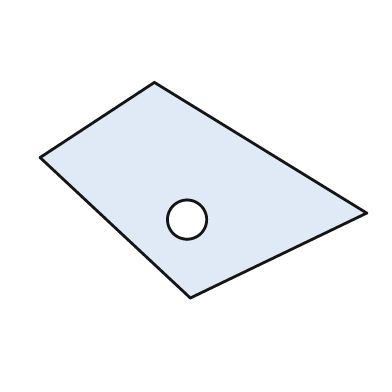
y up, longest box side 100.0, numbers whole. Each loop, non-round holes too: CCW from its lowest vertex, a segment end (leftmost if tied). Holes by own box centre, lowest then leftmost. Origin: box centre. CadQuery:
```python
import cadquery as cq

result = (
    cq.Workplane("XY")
    .moveTo(-4.0, -33.0)
    .lineTo(50.0, -7.0)
    .lineTo(-15.0, 33.0)
    .lineTo(-50.0, 10.0)
    .close()
    .moveTo(-5.0, -9.0)
    .circle(6.0)
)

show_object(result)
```